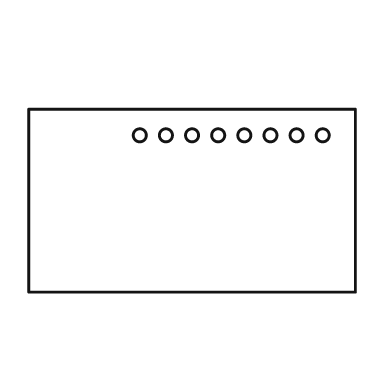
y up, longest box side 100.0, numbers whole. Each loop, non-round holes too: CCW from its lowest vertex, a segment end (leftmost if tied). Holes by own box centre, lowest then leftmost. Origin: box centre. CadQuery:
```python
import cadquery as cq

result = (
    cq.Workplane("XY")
    .moveTo(-50.0, -28.0)
    .lineTo(50.0, -28.0)
    .lineTo(50.0, 28.0)
    .lineTo(-50.0, 28.0)
    .close()
    .moveTo(-16.0, 20.0)
    .circle(2.0)
    .moveTo(-8.0, 20.0)
    .circle(2.0)
    .moveTo(0.0, 20.0)
    .circle(2.0)
    .moveTo(8.0, 20.0)
    .circle(2.0)
    .moveTo(16.0, 20.0)
    .circle(2.0)
    .moveTo(24.0, 20.0)
    .circle(2.0)
    .moveTo(32.0, 20.0)
    .circle(2.0)
    .moveTo(40.0, 20.0)
    .circle(2.0)
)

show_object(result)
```